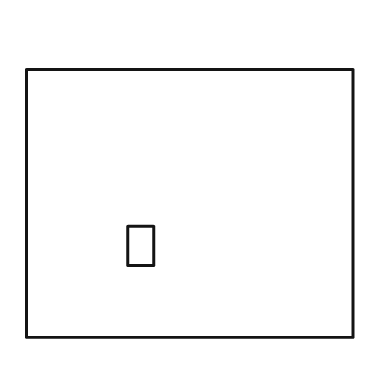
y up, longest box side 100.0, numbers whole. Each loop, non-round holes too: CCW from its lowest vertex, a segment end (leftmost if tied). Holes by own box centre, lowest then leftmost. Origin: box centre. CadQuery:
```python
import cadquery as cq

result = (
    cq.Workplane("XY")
    .moveTo(-50.0, -41.0)
    .lineTo(50.0, -41.0)
    .lineTo(50.0, 41.0)
    .lineTo(-50.0, 41.0)
    .close()
    .moveTo(-19.0, -19.0)
    .lineTo(-11.0, -19.0)
    .lineTo(-11.0, -7.0)
    .lineTo(-19.0, -7.0)
    .close()
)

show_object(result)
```